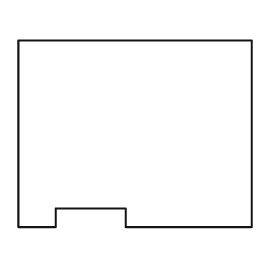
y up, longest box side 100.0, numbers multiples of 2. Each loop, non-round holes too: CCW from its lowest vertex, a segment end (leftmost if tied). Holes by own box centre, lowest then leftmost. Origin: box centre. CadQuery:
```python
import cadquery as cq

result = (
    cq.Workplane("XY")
    .moveTo(-50.0, -40.0)
    .lineTo(-34.0, -40.0)
    .lineTo(-34.0, -32.0)
    .lineTo(-4.0, -32.0)
    .lineTo(-4.0, -40.0)
    .lineTo(50.0, -40.0)
    .lineTo(50.0, 40.0)
    .lineTo(-50.0, 40.0)
    .close()
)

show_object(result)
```